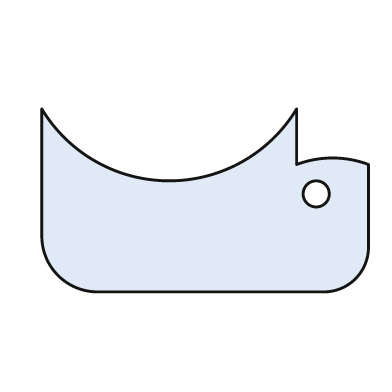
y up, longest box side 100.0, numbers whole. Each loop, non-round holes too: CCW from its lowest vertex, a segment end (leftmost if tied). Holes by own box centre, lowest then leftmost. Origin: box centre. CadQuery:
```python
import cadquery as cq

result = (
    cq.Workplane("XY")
    .moveTo(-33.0, -28.0)
    .lineTo(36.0, -28.0)
    .threePointArc((46.0, -24.0), (50.0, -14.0))
    .lineTo(50.0, 11.0)
    .threePointArc((39.0, 13.0), (28.0, 11.0))
    .lineTo(28.0, 28.0)
    .threePointArc((-11.0, 6.0), (-50.0, 28.0))
    .lineTo(-50.0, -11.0)
    .threePointArc((-45.0, -23.0), (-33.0, -28.0))
    .close()
    .moveTo(34.0, 2.0)
    .circle(4.0)
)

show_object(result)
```